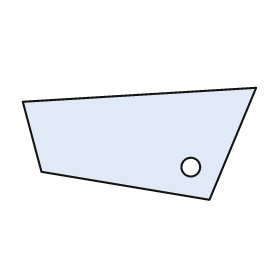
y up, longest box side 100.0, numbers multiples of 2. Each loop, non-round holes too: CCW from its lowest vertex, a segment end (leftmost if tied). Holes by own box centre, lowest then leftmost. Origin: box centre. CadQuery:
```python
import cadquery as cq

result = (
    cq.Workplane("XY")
    .moveTo(30.0, -24.0)
    .lineTo(50.0, 24.0)
    .lineTo(-50.0, 18.0)
    .lineTo(-42.0, -12.0)
    .close()
    .moveTo(22.0, -10.0)
    .circle(4.0)
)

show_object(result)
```